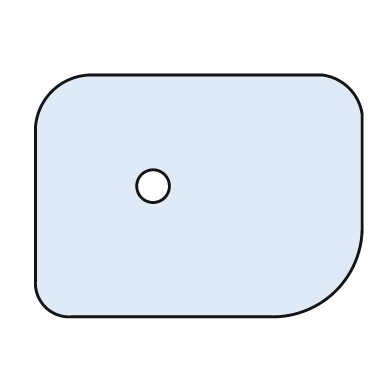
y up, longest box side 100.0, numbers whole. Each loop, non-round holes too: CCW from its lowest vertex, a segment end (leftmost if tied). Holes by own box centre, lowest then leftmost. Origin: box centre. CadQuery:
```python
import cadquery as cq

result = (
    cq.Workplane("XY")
    .moveTo(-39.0, -37.0)
    .lineTo(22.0, -37.0)
    .threePointArc((42.0, -29.0), (50.0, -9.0))
    .lineTo(50.0, 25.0)
    .threePointArc((46.0, 33.0), (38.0, 37.0))
    .lineTo(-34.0, 37.0)
    .threePointArc((-45.0, 32.0), (-50.0, 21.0))
    .lineTo(-50.0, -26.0)
    .threePointArc((-47.0, -34.0), (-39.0, -37.0))
    .close()
    .moveTo(-14.0, 3.0)
    .circle(5.0)
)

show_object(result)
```